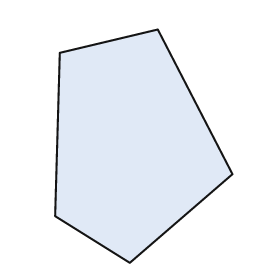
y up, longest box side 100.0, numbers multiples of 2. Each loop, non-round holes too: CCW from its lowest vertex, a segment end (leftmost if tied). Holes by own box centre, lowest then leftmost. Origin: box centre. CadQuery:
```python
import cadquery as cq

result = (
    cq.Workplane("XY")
    .moveTo(-6.0, -50.0)
    .lineTo(38.0, -12.0)
    .lineTo(6.0, 50.0)
    .lineTo(-36.0, 40.0)
    .lineTo(-38.0, -30.0)
    .close()
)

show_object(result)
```